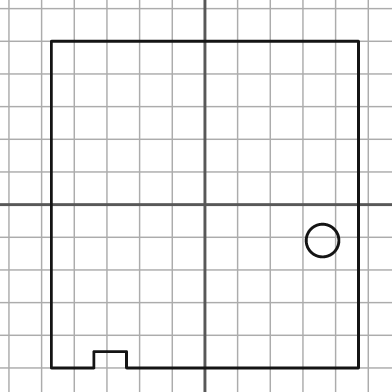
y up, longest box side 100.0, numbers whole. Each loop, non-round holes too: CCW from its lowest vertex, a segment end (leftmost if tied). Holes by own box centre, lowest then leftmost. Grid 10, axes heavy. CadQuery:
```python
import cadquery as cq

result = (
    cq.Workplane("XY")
    .moveTo(-47.0, -50.0)
    .lineTo(-34.0, -50.0)
    .lineTo(-34.0, -45.0)
    .lineTo(-24.0, -45.0)
    .lineTo(-24.0, -50.0)
    .lineTo(47.0, -50.0)
    .lineTo(47.0, 50.0)
    .lineTo(-47.0, 50.0)
    .close()
    .moveTo(36.0, -11.0)
    .circle(5.0)
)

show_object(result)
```